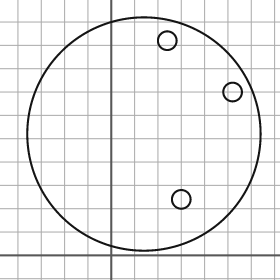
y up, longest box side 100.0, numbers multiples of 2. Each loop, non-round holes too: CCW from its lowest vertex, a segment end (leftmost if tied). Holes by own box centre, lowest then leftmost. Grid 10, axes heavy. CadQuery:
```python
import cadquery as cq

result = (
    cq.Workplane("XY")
    .moveTo(14.0, 52.0)
    .circle(50.0)
    .moveTo(30.0, 24.0)
    .circle(4.0)
    .moveTo(52.0, 70.0)
    .circle(4.0)
    .moveTo(24.0, 92.0)
    .circle(4.0)
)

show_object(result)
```